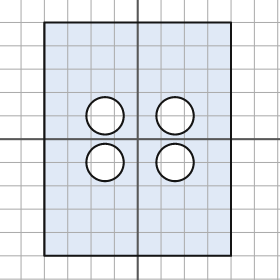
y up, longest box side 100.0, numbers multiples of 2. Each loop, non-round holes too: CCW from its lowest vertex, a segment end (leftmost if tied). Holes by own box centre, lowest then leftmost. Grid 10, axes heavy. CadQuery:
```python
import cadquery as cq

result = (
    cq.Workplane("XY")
    .moveTo(-40.0, -50.0)
    .lineTo(40.0, -50.0)
    .lineTo(40.0, 50.0)
    .lineTo(-40.0, 50.0)
    .close()
    .moveTo(-14.0, -10.0)
    .circle(8.0)
    .moveTo(16.0, -10.0)
    .circle(8.0)
    .moveTo(-14.0, 10.0)
    .circle(8.0)
    .moveTo(16.0, 10.0)
    .circle(8.0)
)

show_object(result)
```